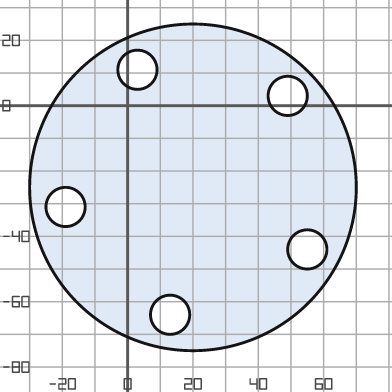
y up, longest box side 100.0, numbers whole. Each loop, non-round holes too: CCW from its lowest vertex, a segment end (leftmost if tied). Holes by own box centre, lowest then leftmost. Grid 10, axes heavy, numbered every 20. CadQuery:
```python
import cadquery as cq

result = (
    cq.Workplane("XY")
    .moveTo(20.0, -25.0)
    .circle(50.0)
    .moveTo(13.0, -64.0)
    .circle(6.0)
    .moveTo(55.0, -44.0)
    .circle(6.0)
    .moveTo(-19.0, -31.0)
    .circle(6.0)
    .moveTo(49.0, 3.0)
    .circle(6.0)
    .moveTo(3.0, 11.0)
    .circle(6.0)
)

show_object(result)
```